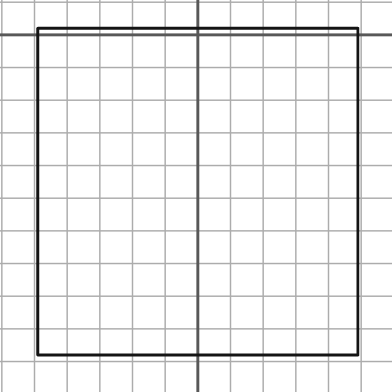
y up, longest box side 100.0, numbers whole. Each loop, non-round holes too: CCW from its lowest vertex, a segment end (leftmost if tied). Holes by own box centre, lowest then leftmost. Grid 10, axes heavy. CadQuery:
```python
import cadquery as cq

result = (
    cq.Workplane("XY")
    .moveTo(-49.0, -98.0)
    .lineTo(49.0, -98.0)
    .lineTo(49.0, 2.0)
    .lineTo(-49.0, 2.0)
    .close()
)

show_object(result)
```